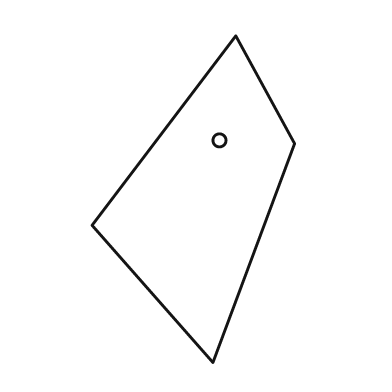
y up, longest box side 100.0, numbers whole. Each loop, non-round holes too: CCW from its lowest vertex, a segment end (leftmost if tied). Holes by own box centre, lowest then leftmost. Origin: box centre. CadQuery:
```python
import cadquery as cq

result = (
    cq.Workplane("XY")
    .moveTo(6.0, -50.0)
    .lineTo(31.0, 17.0)
    .lineTo(13.0, 50.0)
    .lineTo(-31.0, -8.0)
    .close()
    .moveTo(8.0, 18.0)
    .circle(2.0)
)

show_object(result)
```